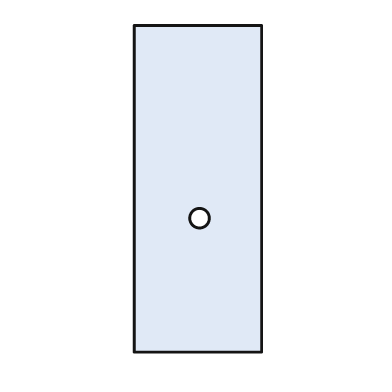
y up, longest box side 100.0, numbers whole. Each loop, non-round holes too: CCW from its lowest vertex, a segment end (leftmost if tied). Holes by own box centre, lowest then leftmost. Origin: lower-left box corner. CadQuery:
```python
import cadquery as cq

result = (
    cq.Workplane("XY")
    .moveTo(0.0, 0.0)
    .lineTo(39.0, 0.0)
    .lineTo(39.0, 100.0)
    .lineTo(0.0, 100.0)
    .close()
    .moveTo(20.0, 41.0)
    .circle(3.0)
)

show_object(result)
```